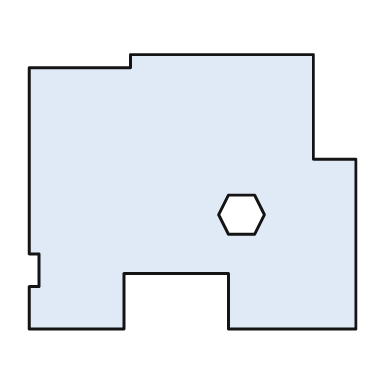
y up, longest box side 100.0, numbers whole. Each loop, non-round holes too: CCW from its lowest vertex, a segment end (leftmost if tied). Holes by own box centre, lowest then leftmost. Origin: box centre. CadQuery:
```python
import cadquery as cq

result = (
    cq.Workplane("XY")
    .moveTo(-50.0, -42.0)
    .lineTo(-21.0, -42.0)
    .lineTo(-21.0, -25.0)
    .lineTo(11.0, -25.0)
    .lineTo(11.0, -42.0)
    .lineTo(50.0, -42.0)
    .lineTo(50.0, 10.0)
    .lineTo(37.0, 10.0)
    .lineTo(37.0, 42.0)
    .lineTo(-19.0, 42.0)
    .lineTo(-19.0, 38.0)
    .lineTo(-50.0, 38.0)
    .lineTo(-50.0, -19.0)
    .lineTo(-47.0, -19.0)
    .lineTo(-47.0, -29.0)
    .lineTo(-50.0, -29.0)
    .close()
    .moveTo(11.0, -13.0)
    .lineTo(19.0, -13.0)
    .lineTo(22.0, -7.0)
    .lineTo(19.0, -1.0)
    .lineTo(11.0, -1.0)
    .lineTo(8.0, -7.0)
    .close()
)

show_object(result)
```